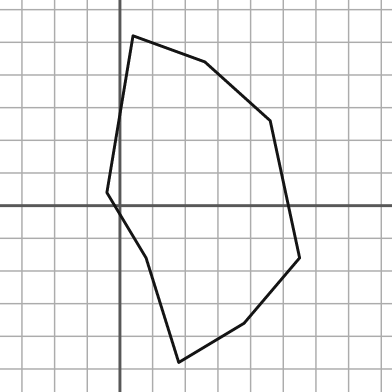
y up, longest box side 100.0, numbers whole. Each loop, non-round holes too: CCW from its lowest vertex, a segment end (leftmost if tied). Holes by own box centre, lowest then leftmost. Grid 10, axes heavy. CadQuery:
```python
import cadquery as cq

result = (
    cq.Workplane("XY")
    .moveTo(18.0, -48.0)
    .lineTo(38.0, -36.0)
    .lineTo(55.0, -16.0)
    .lineTo(46.0, 26.0)
    .lineTo(26.0, 44.0)
    .lineTo(4.0, 52.0)
    .lineTo(-4.0, 4.0)
    .lineTo(8.0, -16.0)
    .close()
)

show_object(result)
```